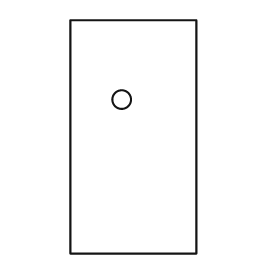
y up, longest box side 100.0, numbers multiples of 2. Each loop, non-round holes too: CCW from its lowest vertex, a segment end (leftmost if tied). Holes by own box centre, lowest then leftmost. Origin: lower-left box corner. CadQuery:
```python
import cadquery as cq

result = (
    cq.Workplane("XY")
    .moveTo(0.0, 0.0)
    .lineTo(54.0, 0.0)
    .lineTo(54.0, 100.0)
    .lineTo(0.0, 100.0)
    .close()
    .moveTo(22.0, 66.0)
    .circle(4.0)
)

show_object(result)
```